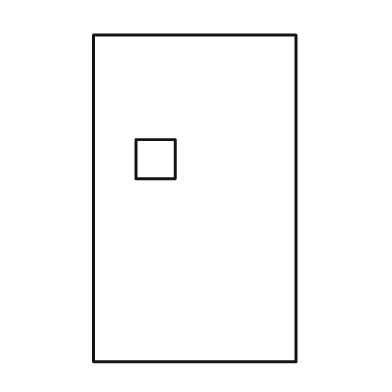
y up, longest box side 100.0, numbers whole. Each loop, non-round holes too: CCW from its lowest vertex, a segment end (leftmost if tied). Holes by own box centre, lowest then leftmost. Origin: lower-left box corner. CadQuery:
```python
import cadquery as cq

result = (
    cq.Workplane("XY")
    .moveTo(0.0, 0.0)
    .lineTo(62.0, 0.0)
    .lineTo(62.0, 100.0)
    .lineTo(0.0, 100.0)
    .close()
    .moveTo(13.0, 56.0)
    .lineTo(25.0, 56.0)
    .lineTo(25.0, 68.0)
    .lineTo(13.0, 68.0)
    .close()
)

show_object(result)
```